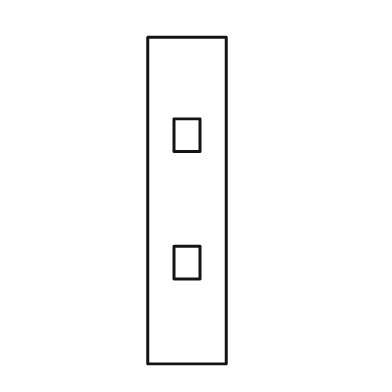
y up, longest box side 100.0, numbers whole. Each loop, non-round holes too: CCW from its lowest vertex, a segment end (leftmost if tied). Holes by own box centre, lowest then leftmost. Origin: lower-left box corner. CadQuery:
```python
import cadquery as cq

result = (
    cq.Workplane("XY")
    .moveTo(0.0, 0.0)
    .lineTo(24.0, 0.0)
    .lineTo(24.0, 100.0)
    .lineTo(0.0, 100.0)
    .close()
    .moveTo(8.0, 26.0)
    .lineTo(16.0, 26.0)
    .lineTo(16.0, 36.0)
    .lineTo(8.0, 36.0)
    .close()
    .moveTo(8.0, 65.0)
    .lineTo(16.0, 65.0)
    .lineTo(16.0, 75.0)
    .lineTo(8.0, 75.0)
    .close()
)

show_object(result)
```